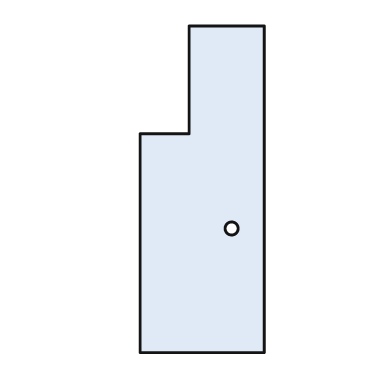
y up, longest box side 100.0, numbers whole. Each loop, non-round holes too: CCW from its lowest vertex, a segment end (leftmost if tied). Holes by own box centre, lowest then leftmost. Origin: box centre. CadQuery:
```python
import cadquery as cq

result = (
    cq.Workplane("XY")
    .moveTo(-19.0, -50.0)
    .lineTo(19.0, -50.0)
    .lineTo(19.0, 50.0)
    .lineTo(-4.0, 50.0)
    .lineTo(-4.0, 17.0)
    .lineTo(-19.0, 17.0)
    .close()
    .moveTo(9.0, -12.0)
    .circle(2.0)
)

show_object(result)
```